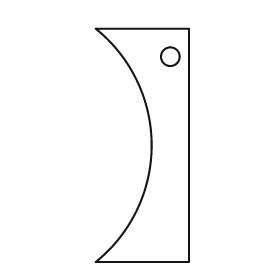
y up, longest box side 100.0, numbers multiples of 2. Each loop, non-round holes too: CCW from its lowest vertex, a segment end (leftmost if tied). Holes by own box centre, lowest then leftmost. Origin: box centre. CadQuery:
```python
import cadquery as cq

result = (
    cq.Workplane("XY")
    .moveTo(-20.0, -50.0)
    .lineTo(20.0, -50.0)
    .lineTo(20.0, 50.0)
    .lineTo(-20.0, 50.0)
    .threePointArc((4.0, 0.0), (-20.0, -50.0))
    .close()
    .moveTo(12.0, 38.0)
    .circle(4.0)
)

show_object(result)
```